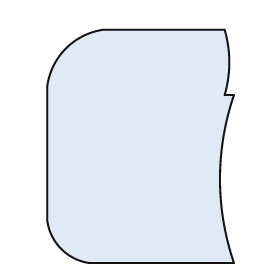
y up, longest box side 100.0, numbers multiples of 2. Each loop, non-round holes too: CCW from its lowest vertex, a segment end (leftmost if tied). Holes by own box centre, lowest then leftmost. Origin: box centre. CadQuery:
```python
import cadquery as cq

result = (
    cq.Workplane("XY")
    .moveTo(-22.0, -50.0)
    .lineTo(40.0, -50.0)
    .threePointArc((34.0, -14.0), (40.0, 22.0))
    .lineTo(36.0, 22.0)
    .threePointArc((38.0, 36.0), (36.0, 50.0))
    .lineTo(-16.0, 50.0)
    .threePointArc((-32.0, 42.0), (-40.0, 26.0))
    .lineTo(-40.0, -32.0)
    .threePointArc((-34.0, -44.0), (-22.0, -50.0))
    .close()
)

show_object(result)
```